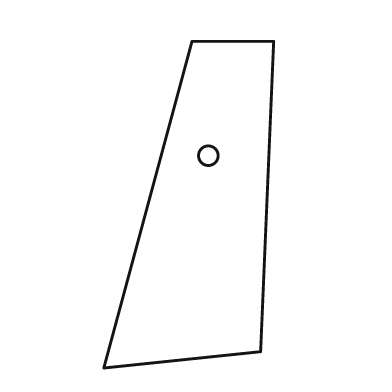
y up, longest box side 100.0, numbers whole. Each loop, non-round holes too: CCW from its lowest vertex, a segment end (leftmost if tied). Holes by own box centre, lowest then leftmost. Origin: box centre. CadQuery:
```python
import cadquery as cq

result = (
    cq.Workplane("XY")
    .moveTo(-26.0, -50.0)
    .lineTo(22.0, -45.0)
    .lineTo(26.0, 50.0)
    .lineTo(1.0, 50.0)
    .close()
    .moveTo(6.0, 15.0)
    .circle(3.0)
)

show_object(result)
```